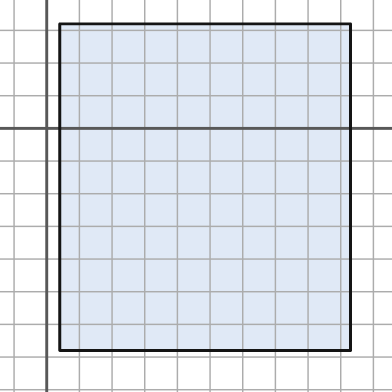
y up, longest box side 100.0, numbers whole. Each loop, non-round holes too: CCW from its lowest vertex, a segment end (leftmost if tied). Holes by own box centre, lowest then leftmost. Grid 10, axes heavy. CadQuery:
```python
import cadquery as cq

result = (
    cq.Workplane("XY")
    .moveTo(4.0, -68.0)
    .lineTo(93.0, -68.0)
    .lineTo(93.0, 32.0)
    .lineTo(4.0, 32.0)
    .close()
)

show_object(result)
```